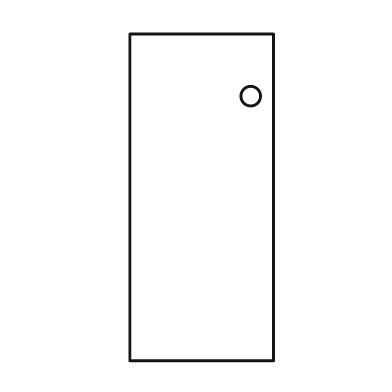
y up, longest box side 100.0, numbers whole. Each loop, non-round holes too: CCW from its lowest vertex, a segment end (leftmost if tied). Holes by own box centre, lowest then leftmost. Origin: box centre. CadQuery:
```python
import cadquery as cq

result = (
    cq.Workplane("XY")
    .moveTo(-22.0, -50.0)
    .lineTo(22.0, -50.0)
    .lineTo(22.0, 50.0)
    .lineTo(-22.0, 50.0)
    .close()
    .moveTo(15.0, 31.0)
    .circle(3.0)
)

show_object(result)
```